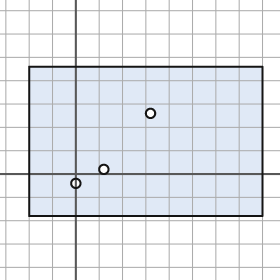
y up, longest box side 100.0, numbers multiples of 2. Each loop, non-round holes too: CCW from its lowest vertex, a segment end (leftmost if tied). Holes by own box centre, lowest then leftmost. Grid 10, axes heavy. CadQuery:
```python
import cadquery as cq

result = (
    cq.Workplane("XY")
    .moveTo(-20.0, -18.0)
    .lineTo(80.0, -18.0)
    .lineTo(80.0, 46.0)
    .lineTo(-20.0, 46.0)
    .close()
    .moveTo(0.0, -4.0)
    .circle(2.0)
    .moveTo(12.0, 2.0)
    .circle(2.0)
    .moveTo(32.0, 26.0)
    .circle(2.0)
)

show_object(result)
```